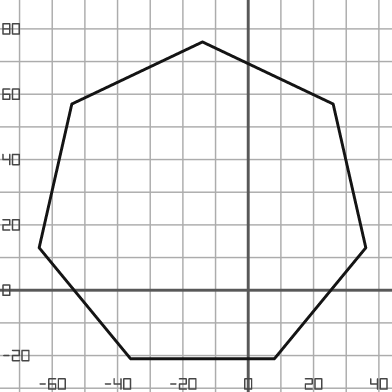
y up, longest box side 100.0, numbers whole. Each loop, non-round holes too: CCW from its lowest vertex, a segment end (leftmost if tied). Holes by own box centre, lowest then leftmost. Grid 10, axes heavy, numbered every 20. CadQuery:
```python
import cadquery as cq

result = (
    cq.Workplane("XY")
    .moveTo(-36.0, -21.0)
    .lineTo(8.0, -21.0)
    .lineTo(36.0, 13.0)
    .lineTo(26.0, 57.0)
    .lineTo(-14.0, 76.0)
    .lineTo(-54.0, 57.0)
    .lineTo(-64.0, 13.0)
    .close()
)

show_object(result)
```